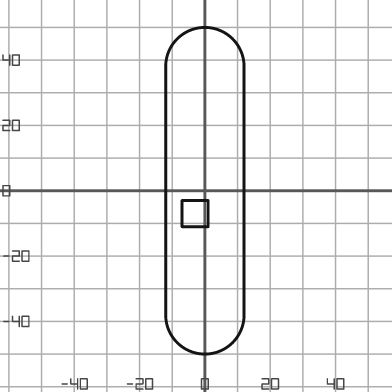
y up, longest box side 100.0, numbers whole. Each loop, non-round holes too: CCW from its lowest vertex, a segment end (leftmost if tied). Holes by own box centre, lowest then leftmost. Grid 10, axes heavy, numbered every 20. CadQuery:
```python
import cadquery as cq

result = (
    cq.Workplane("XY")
    .moveTo(-12.0, -38.0)
    .threePointArc((0.0, -50.0), (12.0, -38.0))
    .lineTo(12.0, 38.0)
    .threePointArc((0.0, 50.0), (-12.0, 38.0))
    .close()
    .moveTo(-7.0, -11.0)
    .lineTo(1.0, -11.0)
    .lineTo(1.0, -3.0)
    .lineTo(-7.0, -3.0)
    .close()
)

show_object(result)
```